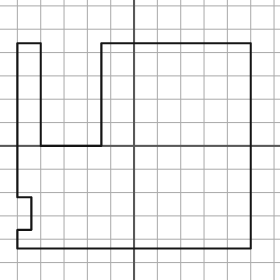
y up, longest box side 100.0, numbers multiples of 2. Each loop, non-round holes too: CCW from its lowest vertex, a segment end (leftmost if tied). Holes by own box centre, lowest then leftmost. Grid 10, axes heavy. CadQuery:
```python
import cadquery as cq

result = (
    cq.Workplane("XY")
    .moveTo(-50.0, -44.0)
    .lineTo(50.0, -44.0)
    .lineTo(50.0, 44.0)
    .lineTo(-14.0, 44.0)
    .lineTo(-14.0, 0.0)
    .lineTo(-40.0, 0.0)
    .lineTo(-40.0, 44.0)
    .lineTo(-50.0, 44.0)
    .lineTo(-50.0, -22.0)
    .lineTo(-44.0, -22.0)
    .lineTo(-44.0, -36.0)
    .lineTo(-50.0, -36.0)
    .close()
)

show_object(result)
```